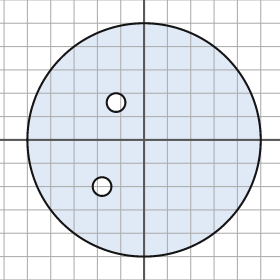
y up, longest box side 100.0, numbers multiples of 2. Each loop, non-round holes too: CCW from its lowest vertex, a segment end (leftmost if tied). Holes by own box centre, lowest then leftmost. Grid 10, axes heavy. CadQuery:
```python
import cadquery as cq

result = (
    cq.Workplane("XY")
    .moveTo(0.0, 0.0)
    .circle(50.0)
    .moveTo(-18.0, -20.0)
    .circle(4.0)
    .moveTo(-12.0, 16.0)
    .circle(4.0)
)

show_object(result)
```